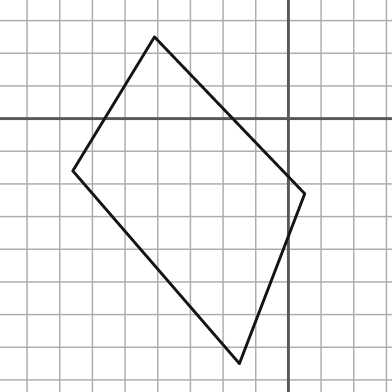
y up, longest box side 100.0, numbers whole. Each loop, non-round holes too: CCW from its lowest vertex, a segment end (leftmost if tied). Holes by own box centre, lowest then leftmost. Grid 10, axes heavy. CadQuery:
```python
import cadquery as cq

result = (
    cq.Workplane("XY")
    .moveTo(-15.0, -75.0)
    .lineTo(5.0, -23.0)
    .lineTo(-41.0, 25.0)
    .lineTo(-66.0, -16.0)
    .close()
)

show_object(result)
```